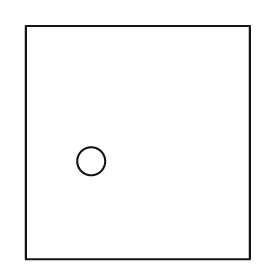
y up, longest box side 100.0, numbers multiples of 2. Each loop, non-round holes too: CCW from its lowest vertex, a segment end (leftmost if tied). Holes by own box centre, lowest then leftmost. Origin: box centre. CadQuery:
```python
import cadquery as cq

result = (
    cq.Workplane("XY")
    .moveTo(-48.0, -50.0)
    .lineTo(48.0, -50.0)
    .lineTo(48.0, 50.0)
    .lineTo(-48.0, 50.0)
    .close()
    .moveTo(-20.0, -8.0)
    .circle(6.0)
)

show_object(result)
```